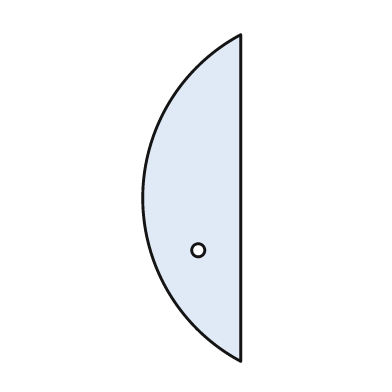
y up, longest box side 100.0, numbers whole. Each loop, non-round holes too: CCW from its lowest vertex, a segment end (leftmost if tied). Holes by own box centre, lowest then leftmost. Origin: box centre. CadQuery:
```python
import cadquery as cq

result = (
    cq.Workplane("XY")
    .moveTo(15.0, -50.0)
    .lineTo(15.0, 50.0)
    .threePointArc((-15.0, 0.0), (15.0, -50.0))
    .close()
    .moveTo(2.0, -16.0)
    .circle(2.0)
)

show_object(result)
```